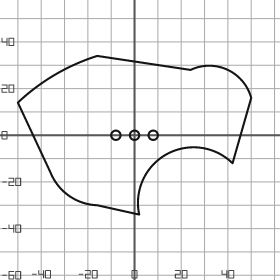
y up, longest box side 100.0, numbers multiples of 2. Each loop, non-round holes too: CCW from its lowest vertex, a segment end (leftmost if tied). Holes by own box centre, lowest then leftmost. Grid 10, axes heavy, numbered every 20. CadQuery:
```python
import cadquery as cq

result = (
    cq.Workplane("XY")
    .moveTo(2.0, -34.0)
    .threePointArc((14.0, -8.0), (42.0, -12.0))
    .lineTo(50.0, 16.0)
    .threePointArc((40.0, 28.0), (24.0, 28.0))
    .lineTo(-16.0, 34.0)
    .threePointArc((-34.0, 26.0), (-50.0, 14.0))
    .lineTo(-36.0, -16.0)
    .threePointArc((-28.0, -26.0), (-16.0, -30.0))
    .close()
    .moveTo(-8.0, 0.0)
    .circle(2.0)
    .moveTo(0.0, 0.0)
    .circle(2.0)
    .moveTo(8.0, 0.0)
    .circle(2.0)
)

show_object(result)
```